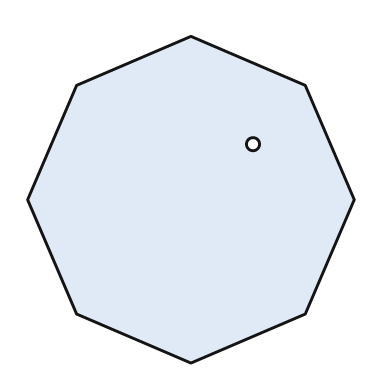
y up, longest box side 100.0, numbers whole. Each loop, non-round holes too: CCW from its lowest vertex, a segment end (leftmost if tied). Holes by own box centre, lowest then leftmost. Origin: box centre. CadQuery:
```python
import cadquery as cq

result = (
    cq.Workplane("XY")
    .moveTo(0.0, -50.0)
    .lineTo(35.0, -35.0)
    .lineTo(50.0, 0.0)
    .lineTo(35.0, 35.0)
    .lineTo(0.0, 50.0)
    .lineTo(-35.0, 35.0)
    .lineTo(-50.0, 0.0)
    .lineTo(-35.0, -35.0)
    .close()
    .moveTo(19.0, 17.0)
    .circle(2.0)
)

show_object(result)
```